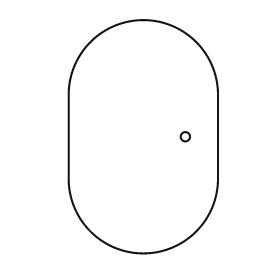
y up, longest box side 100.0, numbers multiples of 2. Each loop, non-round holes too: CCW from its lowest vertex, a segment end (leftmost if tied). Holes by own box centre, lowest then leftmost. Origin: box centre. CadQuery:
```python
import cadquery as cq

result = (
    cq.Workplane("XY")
    .moveTo(-32.0, -18.0)
    .threePointArc((0.0, -50.0), (32.0, -18.0))
    .lineTo(32.0, 18.0)
    .threePointArc((0.0, 50.0), (-32.0, 18.0))
    .close()
    .moveTo(18.0, 0.0)
    .circle(2.0)
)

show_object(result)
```